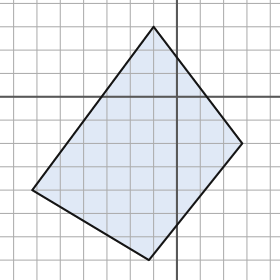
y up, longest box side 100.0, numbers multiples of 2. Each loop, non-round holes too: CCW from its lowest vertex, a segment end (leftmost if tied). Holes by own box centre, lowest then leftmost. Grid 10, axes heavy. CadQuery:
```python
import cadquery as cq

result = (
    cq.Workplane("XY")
    .moveTo(-12.0, -70.0)
    .lineTo(28.0, -20.0)
    .lineTo(-10.0, 30.0)
    .lineTo(-62.0, -40.0)
    .close()
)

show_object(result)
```